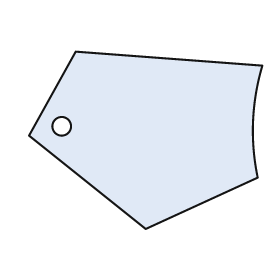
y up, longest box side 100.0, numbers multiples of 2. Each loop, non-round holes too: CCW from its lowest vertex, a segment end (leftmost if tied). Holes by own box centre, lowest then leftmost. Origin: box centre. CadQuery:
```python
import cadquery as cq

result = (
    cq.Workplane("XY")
    .moveTo(0.0, -38.0)
    .lineTo(48.0, -16.0)
    .threePointArc((46.0, 8.0), (50.0, 32.0))
    .lineTo(-30.0, 38.0)
    .lineTo(-50.0, 2.0)
    .close()
    .moveTo(-36.0, 6.0)
    .circle(4.0)
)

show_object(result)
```